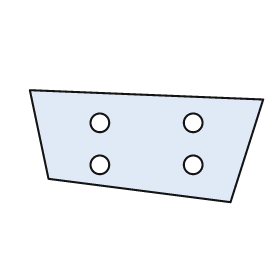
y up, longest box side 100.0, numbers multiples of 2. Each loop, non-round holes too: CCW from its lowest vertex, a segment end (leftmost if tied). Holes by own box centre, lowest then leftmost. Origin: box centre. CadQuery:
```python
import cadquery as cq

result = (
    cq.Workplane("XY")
    .moveTo(36.0, -24.0)
    .lineTo(50.0, 20.0)
    .lineTo(-50.0, 24.0)
    .lineTo(-42.0, -14.0)
    .close()
    .moveTo(-20.0, -8.0)
    .circle(4.0)
    .moveTo(20.0, -8.0)
    .circle(4.0)
    .moveTo(-20.0, 10.0)
    .circle(4.0)
    .moveTo(20.0, 10.0)
    .circle(4.0)
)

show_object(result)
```